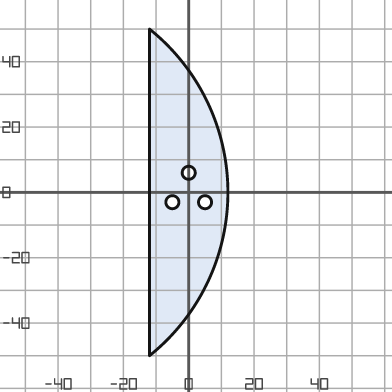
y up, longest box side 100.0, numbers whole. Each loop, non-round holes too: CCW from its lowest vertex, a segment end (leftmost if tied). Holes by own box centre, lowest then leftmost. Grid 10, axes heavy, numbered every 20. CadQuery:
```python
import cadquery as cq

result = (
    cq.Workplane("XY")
    .moveTo(-12.0, -50.0)
    .threePointArc((12.0, 0.0), (-12.0, 50.0))
    .close()
    .moveTo(-5.0, -3.0)
    .circle(2.0)
    .moveTo(5.0, -3.0)
    .circle(2.0)
    .moveTo(0.0, 6.0)
    .circle(2.0)
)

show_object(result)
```